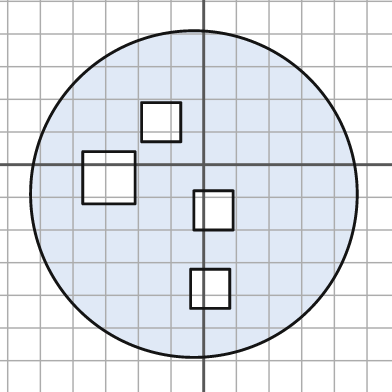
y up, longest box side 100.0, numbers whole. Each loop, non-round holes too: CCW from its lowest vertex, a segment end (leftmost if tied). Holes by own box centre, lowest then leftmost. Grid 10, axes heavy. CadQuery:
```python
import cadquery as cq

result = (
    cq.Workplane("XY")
    .moveTo(-3.0, -9.0)
    .circle(50.0)
    .moveTo(-4.0, -44.0)
    .lineTo(8.0, -44.0)
    .lineTo(8.0, -32.0)
    .lineTo(-4.0, -32.0)
    .close()
    .moveTo(-3.0, -20.0)
    .lineTo(9.0, -20.0)
    .lineTo(9.0, -8.0)
    .lineTo(-3.0, -8.0)
    .close()
    .moveTo(-37.0, -12.0)
    .lineTo(-21.0, -12.0)
    .lineTo(-21.0, 4.0)
    .lineTo(-37.0, 4.0)
    .close()
    .moveTo(-19.0, 7.0)
    .lineTo(-7.0, 7.0)
    .lineTo(-7.0, 19.0)
    .lineTo(-19.0, 19.0)
    .close()
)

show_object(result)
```